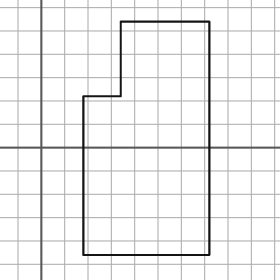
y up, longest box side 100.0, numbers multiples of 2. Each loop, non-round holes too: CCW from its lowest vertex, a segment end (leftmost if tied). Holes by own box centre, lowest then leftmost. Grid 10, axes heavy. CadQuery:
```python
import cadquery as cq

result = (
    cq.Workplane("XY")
    .moveTo(18.0, -46.0)
    .lineTo(72.0, -46.0)
    .lineTo(72.0, 54.0)
    .lineTo(34.0, 54.0)
    .lineTo(34.0, 22.0)
    .lineTo(18.0, 22.0)
    .close()
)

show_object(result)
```